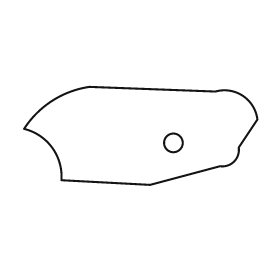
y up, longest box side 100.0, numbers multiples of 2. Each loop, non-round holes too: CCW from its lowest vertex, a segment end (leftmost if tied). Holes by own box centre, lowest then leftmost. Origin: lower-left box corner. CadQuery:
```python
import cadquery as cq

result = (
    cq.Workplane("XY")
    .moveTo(54.0, 0.0)
    .lineTo(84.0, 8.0)
    .threePointArc((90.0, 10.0), (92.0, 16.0))
    .lineTo(100.0, 28.0)
    .threePointArc((94.0, 38.0), (82.0, 40.0))
    .lineTo(28.0, 42.0)
    .threePointArc((12.0, 36.0), (0.0, 24.0))
    .threePointArc((12.0, 16.0), (16.0, 2.0))
    .close()
    .moveTo(64.0, 18.0)
    .circle(4.0)
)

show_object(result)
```